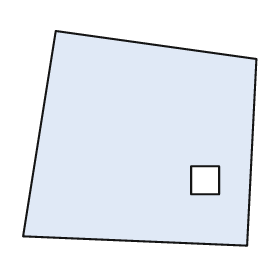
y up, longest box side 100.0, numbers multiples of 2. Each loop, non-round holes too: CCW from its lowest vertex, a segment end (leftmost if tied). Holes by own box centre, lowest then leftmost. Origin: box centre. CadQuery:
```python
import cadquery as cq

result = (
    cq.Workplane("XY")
    .moveTo(46.0, -46.0)
    .lineTo(50.0, 34.0)
    .lineTo(-36.0, 46.0)
    .lineTo(-50.0, -42.0)
    .close()
    .moveTo(22.0, -24.0)
    .lineTo(34.0, -24.0)
    .lineTo(34.0, -12.0)
    .lineTo(22.0, -12.0)
    .close()
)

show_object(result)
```